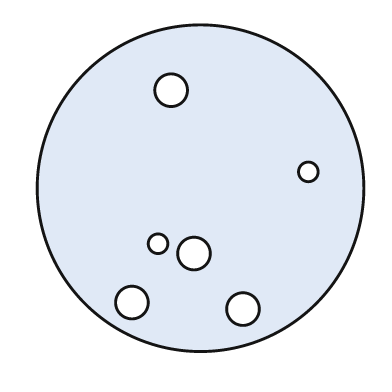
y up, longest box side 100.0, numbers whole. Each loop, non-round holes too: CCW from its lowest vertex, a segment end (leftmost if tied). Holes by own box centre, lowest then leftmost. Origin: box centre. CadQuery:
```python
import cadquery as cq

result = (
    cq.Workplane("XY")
    .moveTo(0.0, 0.0)
    .circle(50.0)
    .moveTo(13.0, -37.0)
    .circle(5.0)
    .moveTo(-21.0, -35.0)
    .circle(5.0)
    .moveTo(-2.0, -20.0)
    .circle(5.0)
    .moveTo(-13.0, -17.0)
    .circle(3.0)
    .moveTo(33.0, 5.0)
    .circle(3.0)
    .moveTo(-9.0, 30.0)
    .circle(5.0)
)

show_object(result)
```